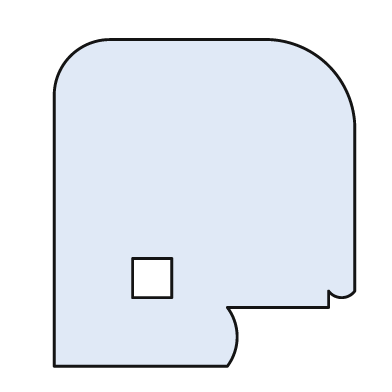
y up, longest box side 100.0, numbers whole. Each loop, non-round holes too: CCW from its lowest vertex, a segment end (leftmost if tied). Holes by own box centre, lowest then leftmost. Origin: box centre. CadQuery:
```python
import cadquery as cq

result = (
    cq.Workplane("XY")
    .moveTo(-46.0, -50.0)
    .lineTo(7.0, -50.0)
    .threePointArc((10.0, -41.0), (7.0, -32.0))
    .lineTo(38.0, -32.0)
    .lineTo(38.0, -27.0)
    .threePointArc((42.0, -29.0), (46.0, -27.0))
    .lineTo(46.0, 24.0)
    .threePointArc((38.0, 42.0), (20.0, 50.0))
    .lineTo(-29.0, 50.0)
    .threePointArc((-41.0, 45.0), (-46.0, 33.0))
    .close()
    .moveTo(-22.0, -29.0)
    .lineTo(-10.0, -29.0)
    .lineTo(-10.0, -17.0)
    .lineTo(-22.0, -17.0)
    .close()
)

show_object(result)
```